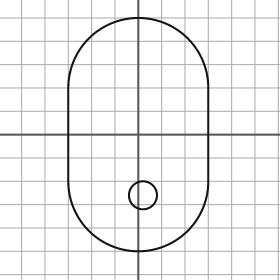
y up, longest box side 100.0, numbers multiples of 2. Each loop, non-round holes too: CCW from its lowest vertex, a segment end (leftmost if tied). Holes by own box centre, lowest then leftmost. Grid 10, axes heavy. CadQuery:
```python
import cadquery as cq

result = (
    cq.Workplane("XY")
    .moveTo(-30.0, -20.0)
    .threePointArc((0.0, -50.0), (30.0, -20.0))
    .lineTo(30.0, 20.0)
    .threePointArc((0.0, 50.0), (-30.0, 20.0))
    .close()
    .moveTo(2.0, -26.0)
    .circle(6.0)
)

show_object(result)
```